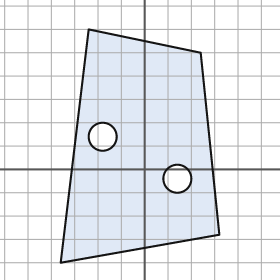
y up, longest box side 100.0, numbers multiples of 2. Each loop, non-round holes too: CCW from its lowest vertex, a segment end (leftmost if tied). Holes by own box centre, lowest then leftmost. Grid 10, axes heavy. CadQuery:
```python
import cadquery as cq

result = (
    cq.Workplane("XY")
    .moveTo(-36.0, -40.0)
    .lineTo(32.0, -28.0)
    .lineTo(24.0, 50.0)
    .lineTo(-24.0, 60.0)
    .close()
    .moveTo(14.0, -4.0)
    .circle(6.0)
    .moveTo(-18.0, 14.0)
    .circle(6.0)
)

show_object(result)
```